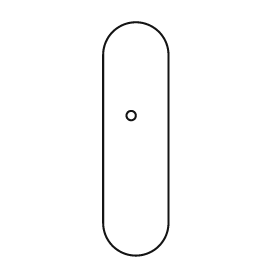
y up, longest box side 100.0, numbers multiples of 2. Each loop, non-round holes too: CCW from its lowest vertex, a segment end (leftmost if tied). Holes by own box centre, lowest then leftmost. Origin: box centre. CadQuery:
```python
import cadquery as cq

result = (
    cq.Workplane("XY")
    .moveTo(-14.0, -36.0)
    .threePointArc((0.0, -50.0), (14.0, -36.0))
    .lineTo(14.0, 36.0)
    .threePointArc((0.0, 50.0), (-14.0, 36.0))
    .close()
    .moveTo(-2.0, 10.0)
    .circle(2.0)
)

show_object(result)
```